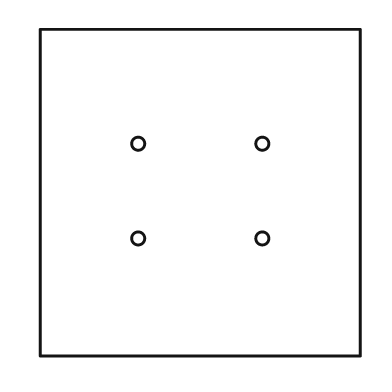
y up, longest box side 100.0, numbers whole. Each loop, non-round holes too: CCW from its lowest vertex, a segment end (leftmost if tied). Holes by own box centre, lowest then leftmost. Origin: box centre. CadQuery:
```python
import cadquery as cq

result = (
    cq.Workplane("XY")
    .moveTo(-49.0, -50.0)
    .lineTo(49.0, -50.0)
    .lineTo(49.0, 50.0)
    .lineTo(-49.0, 50.0)
    .close()
    .moveTo(-19.0, -14.0)
    .circle(2.0)
    .moveTo(19.0, -14.0)
    .circle(2.0)
    .moveTo(-19.0, 15.0)
    .circle(2.0)
    .moveTo(19.0, 15.0)
    .circle(2.0)
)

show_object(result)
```